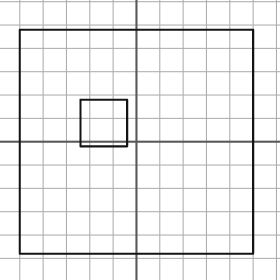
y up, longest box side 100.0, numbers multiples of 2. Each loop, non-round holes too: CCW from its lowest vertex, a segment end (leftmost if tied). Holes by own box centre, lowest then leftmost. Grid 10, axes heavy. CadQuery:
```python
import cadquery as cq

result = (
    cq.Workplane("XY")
    .moveTo(-50.0, -48.0)
    .lineTo(50.0, -48.0)
    .lineTo(50.0, 48.0)
    .lineTo(-50.0, 48.0)
    .close()
    .moveTo(-24.0, -2.0)
    .lineTo(-4.0, -2.0)
    .lineTo(-4.0, 18.0)
    .lineTo(-24.0, 18.0)
    .close()
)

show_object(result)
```